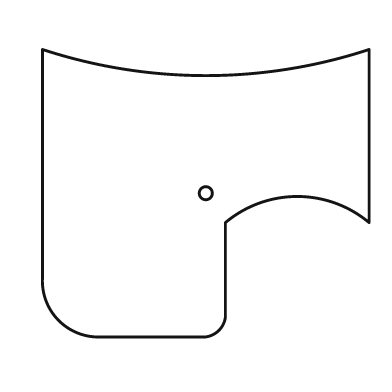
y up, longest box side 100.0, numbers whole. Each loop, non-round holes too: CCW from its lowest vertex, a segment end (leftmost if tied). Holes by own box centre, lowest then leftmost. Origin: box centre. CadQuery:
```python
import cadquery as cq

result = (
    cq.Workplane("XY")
    .moveTo(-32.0, -44.0)
    .lineTo(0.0, -44.0)
    .threePointArc((4.0, -42.0), (6.0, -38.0))
    .lineTo(6.0, -9.0)
    .threePointArc((28.0, -1.0), (50.0, -9.0))
    .lineTo(50.0, 44.0)
    .threePointArc((0.0, 36.0), (-50.0, 44.0))
    .lineTo(-50.0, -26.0)
    .threePointArc((-45.0, -39.0), (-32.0, -44.0))
    .close()
    .moveTo(0.0, 0.0)
    .circle(2.0)
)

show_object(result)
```